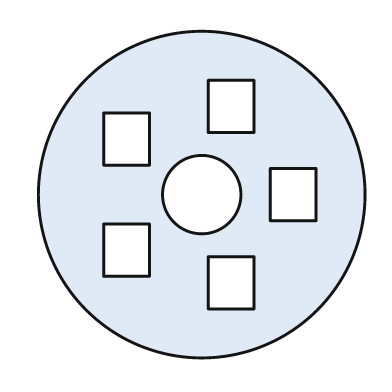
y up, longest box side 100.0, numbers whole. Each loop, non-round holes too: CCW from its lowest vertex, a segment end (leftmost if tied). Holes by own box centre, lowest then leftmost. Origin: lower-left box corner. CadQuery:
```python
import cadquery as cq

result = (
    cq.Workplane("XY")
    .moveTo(50.0, 50.0)
    .circle(50.0)
    .moveTo(52.0, 15.0)
    .lineTo(66.0, 15.0)
    .lineTo(66.0, 31.0)
    .lineTo(52.0, 31.0)
    .close()
    .moveTo(20.0, 25.0)
    .lineTo(34.0, 25.0)
    .lineTo(34.0, 41.0)
    .lineTo(20.0, 41.0)
    .close()
    .moveTo(50.0, 50.0)
    .circle(12.0)
    .moveTo(71.0, 42.0)
    .lineTo(85.0, 42.0)
    .lineTo(85.0, 58.0)
    .lineTo(71.0, 58.0)
    .close()
    .moveTo(20.0, 59.0)
    .lineTo(34.0, 59.0)
    .lineTo(34.0, 75.0)
    .lineTo(20.0, 75.0)
    .close()
    .moveTo(52.0, 69.0)
    .lineTo(66.0, 69.0)
    .lineTo(66.0, 85.0)
    .lineTo(52.0, 85.0)
    .close()
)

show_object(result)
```